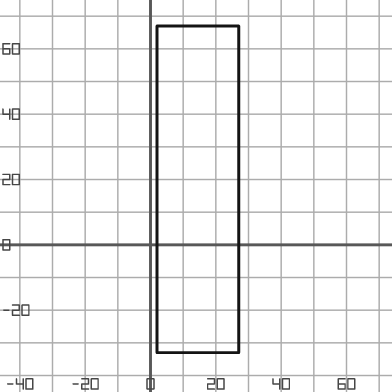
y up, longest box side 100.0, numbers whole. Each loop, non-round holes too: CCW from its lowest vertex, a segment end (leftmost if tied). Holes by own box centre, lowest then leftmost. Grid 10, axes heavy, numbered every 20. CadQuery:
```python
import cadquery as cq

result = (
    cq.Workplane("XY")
    .moveTo(2.0, -33.0)
    .lineTo(27.0, -33.0)
    .lineTo(27.0, 67.0)
    .lineTo(2.0, 67.0)
    .close()
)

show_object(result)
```